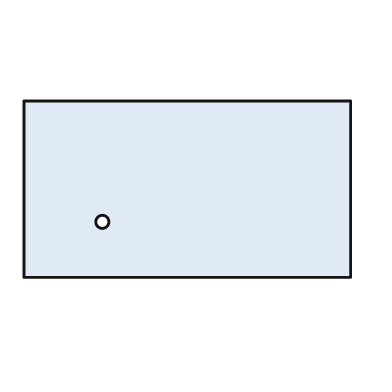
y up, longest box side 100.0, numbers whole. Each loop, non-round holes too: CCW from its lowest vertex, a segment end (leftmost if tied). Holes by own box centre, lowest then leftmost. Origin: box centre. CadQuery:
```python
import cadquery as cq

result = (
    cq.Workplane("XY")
    .moveTo(-50.0, -27.0)
    .lineTo(50.0, -27.0)
    .lineTo(50.0, 27.0)
    .lineTo(-50.0, 27.0)
    .close()
    .moveTo(-26.0, -10.0)
    .circle(2.0)
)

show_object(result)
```